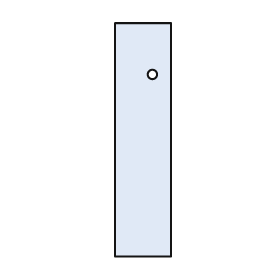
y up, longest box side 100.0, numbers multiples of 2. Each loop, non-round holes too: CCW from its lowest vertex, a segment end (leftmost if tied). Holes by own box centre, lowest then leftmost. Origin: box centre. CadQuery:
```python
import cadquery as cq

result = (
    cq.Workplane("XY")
    .moveTo(-12.0, -50.0)
    .lineTo(12.0, -50.0)
    .lineTo(12.0, 50.0)
    .lineTo(-12.0, 50.0)
    .close()
    .moveTo(4.0, 28.0)
    .circle(2.0)
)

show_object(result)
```